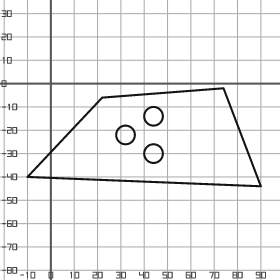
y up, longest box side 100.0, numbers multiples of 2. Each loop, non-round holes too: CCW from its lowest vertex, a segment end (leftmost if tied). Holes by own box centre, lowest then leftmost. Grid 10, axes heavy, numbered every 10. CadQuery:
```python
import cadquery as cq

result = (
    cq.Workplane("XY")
    .moveTo(90.0, -44.0)
    .lineTo(74.0, -2.0)
    .lineTo(22.0, -6.0)
    .lineTo(-10.0, -40.0)
    .close()
    .moveTo(44.0, -30.0)
    .circle(4.0)
    .moveTo(32.0, -22.0)
    .circle(4.0)
    .moveTo(44.0, -14.0)
    .circle(4.0)
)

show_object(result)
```